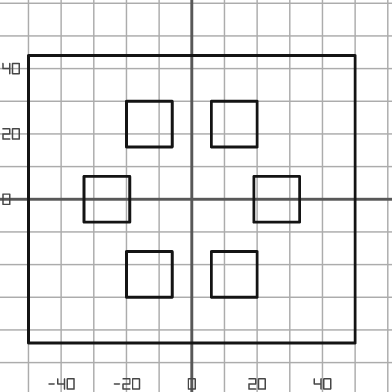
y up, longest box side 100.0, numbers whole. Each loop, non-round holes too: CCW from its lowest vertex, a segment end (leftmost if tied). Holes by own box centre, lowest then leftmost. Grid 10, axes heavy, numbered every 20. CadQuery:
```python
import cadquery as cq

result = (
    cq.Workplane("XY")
    .moveTo(-50.0, -44.0)
    .lineTo(50.0, -44.0)
    .lineTo(50.0, 44.0)
    .lineTo(-50.0, 44.0)
    .close()
    .moveTo(-20.0, -30.0)
    .lineTo(-6.0, -30.0)
    .lineTo(-6.0, -16.0)
    .lineTo(-20.0, -16.0)
    .close()
    .moveTo(6.0, -30.0)
    .lineTo(20.0, -30.0)
    .lineTo(20.0, -16.0)
    .lineTo(6.0, -16.0)
    .close()
    .moveTo(-33.0, -7.0)
    .lineTo(-19.0, -7.0)
    .lineTo(-19.0, 7.0)
    .lineTo(-33.0, 7.0)
    .close()
    .moveTo(19.0, -7.0)
    .lineTo(33.0, -7.0)
    .lineTo(33.0, 7.0)
    .lineTo(19.0, 7.0)
    .close()
    .moveTo(-20.0, 16.0)
    .lineTo(-6.0, 16.0)
    .lineTo(-6.0, 30.0)
    .lineTo(-20.0, 30.0)
    .close()
    .moveTo(6.0, 16.0)
    .lineTo(20.0, 16.0)
    .lineTo(20.0, 30.0)
    .lineTo(6.0, 30.0)
    .close()
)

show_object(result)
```